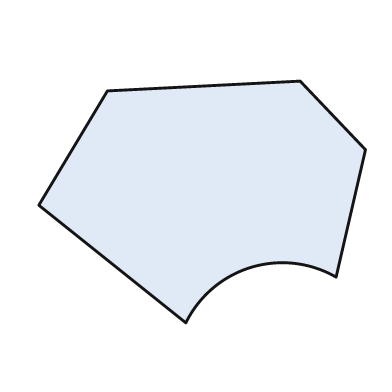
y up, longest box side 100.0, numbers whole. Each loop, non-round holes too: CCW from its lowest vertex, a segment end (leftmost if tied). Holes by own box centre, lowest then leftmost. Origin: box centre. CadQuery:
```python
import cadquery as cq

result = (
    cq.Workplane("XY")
    .moveTo(-5.0, -37.0)
    .threePointArc((15.0, -20.0), (41.0, -23.0))
    .lineTo(50.0, 16.0)
    .lineTo(30.0, 37.0)
    .lineTo(-29.0, 34.0)
    .lineTo(-50.0, -1.0)
    .close()
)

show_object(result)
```